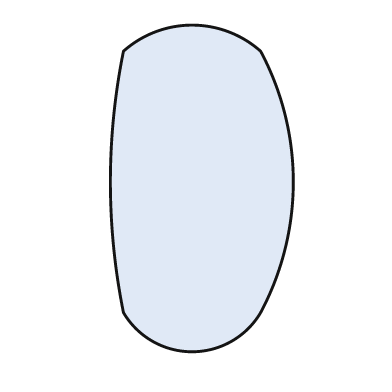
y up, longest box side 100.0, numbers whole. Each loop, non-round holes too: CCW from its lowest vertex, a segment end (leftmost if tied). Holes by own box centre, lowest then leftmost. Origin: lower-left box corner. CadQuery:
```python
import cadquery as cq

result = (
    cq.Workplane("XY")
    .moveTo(4.0, 12.0)
    .threePointArc((25.0, 0.0), (46.0, 12.0))
    .threePointArc((56.0, 52.0), (46.0, 92.0))
    .threePointArc((25.0, 100.0), (4.0, 92.0))
    .threePointArc((0.0, 52.0), (4.0, 12.0))
    .close()
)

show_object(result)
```